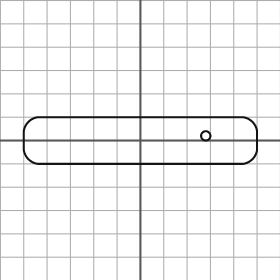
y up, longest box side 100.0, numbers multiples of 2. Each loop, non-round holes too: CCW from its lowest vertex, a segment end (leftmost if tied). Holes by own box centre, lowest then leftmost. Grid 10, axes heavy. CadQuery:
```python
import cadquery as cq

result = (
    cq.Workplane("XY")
    .moveTo(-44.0, -10.0)
    .lineTo(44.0, -10.0)
    .threePointArc((48.0, -8.0), (50.0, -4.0))
    .lineTo(50.0, 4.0)
    .threePointArc((48.0, 8.0), (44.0, 10.0))
    .lineTo(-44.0, 10.0)
    .threePointArc((-48.0, 8.0), (-50.0, 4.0))
    .lineTo(-50.0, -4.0)
    .threePointArc((-48.0, -8.0), (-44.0, -10.0))
    .close()
    .moveTo(28.0, 2.0)
    .circle(2.0)
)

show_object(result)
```